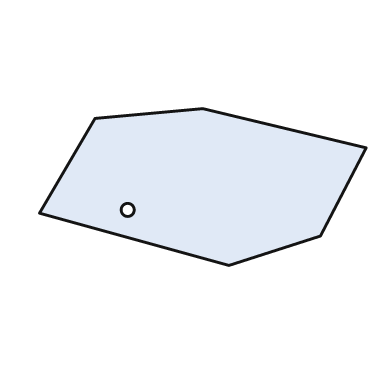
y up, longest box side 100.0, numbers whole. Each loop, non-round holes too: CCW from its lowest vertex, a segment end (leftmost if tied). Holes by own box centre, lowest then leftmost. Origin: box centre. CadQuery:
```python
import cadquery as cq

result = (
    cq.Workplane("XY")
    .moveTo(8.0, -24.0)
    .lineTo(36.0, -15.0)
    .lineTo(50.0, 12.0)
    .lineTo(0.0, 24.0)
    .lineTo(-33.0, 21.0)
    .lineTo(-50.0, -8.0)
    .close()
    .moveTo(-23.0, -7.0)
    .circle(2.0)
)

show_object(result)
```